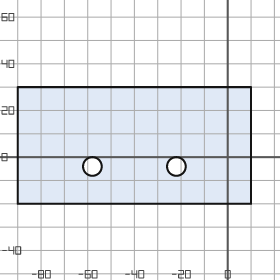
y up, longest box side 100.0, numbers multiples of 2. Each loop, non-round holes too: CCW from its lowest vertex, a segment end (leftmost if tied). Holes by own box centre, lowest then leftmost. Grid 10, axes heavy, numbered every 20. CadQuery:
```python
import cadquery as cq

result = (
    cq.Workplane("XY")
    .moveTo(-90.0, -20.0)
    .lineTo(10.0, -20.0)
    .lineTo(10.0, 30.0)
    .lineTo(-90.0, 30.0)
    .close()
    .moveTo(-58.0, -4.0)
    .circle(4.0)
    .moveTo(-22.0, -4.0)
    .circle(4.0)
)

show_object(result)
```